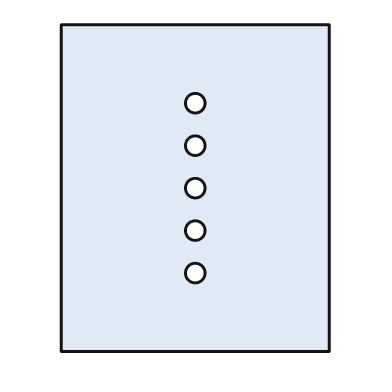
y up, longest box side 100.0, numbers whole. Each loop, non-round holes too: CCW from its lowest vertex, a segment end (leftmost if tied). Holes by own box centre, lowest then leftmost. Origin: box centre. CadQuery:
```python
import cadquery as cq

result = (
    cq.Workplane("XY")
    .moveTo(-41.0, -50.0)
    .lineTo(41.0, -50.0)
    .lineTo(41.0, 50.0)
    .lineTo(-41.0, 50.0)
    .close()
    .moveTo(0.0, -26.0)
    .circle(3.0)
    .moveTo(0.0, -13.0)
    .circle(3.0)
    .moveTo(0.0, 0.0)
    .circle(3.0)
    .moveTo(0.0, 13.0)
    .circle(3.0)
    .moveTo(0.0, 26.0)
    .circle(3.0)
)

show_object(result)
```